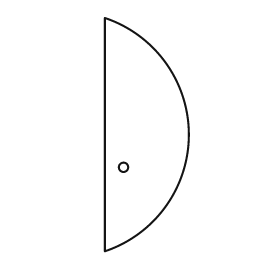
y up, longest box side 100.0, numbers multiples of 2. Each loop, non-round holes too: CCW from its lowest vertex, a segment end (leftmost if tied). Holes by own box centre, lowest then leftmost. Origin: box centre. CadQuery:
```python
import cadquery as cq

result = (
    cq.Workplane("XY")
    .moveTo(-18.0, -50.0)
    .threePointArc((18.0, 0.0), (-18.0, 50.0))
    .close()
    .moveTo(-10.0, -14.0)
    .circle(2.0)
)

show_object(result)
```